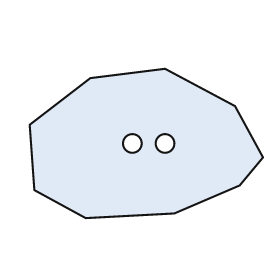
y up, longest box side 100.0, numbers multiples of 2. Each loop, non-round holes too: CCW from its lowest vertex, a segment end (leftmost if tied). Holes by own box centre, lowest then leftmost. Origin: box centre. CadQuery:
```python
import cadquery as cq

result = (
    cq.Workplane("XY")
    .moveTo(-26.0, -32.0)
    .lineTo(12.0, -30.0)
    .lineTo(40.0, -18.0)
    .lineTo(50.0, -6.0)
    .lineTo(38.0, 16.0)
    .lineTo(8.0, 32.0)
    .lineTo(-24.0, 28.0)
    .lineTo(-50.0, 8.0)
    .lineTo(-48.0, -20.0)
    .close()
    .moveTo(-6.0, 0.0)
    .circle(4.0)
    .moveTo(8.0, 0.0)
    .circle(4.0)
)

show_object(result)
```